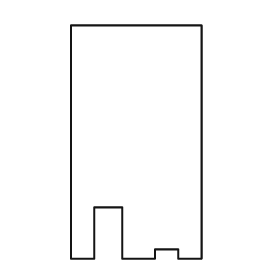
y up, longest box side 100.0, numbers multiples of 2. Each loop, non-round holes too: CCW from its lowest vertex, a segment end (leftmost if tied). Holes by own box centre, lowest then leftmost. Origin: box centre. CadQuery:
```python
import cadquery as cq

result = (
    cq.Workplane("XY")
    .moveTo(-28.0, -50.0)
    .lineTo(-18.0, -50.0)
    .lineTo(-18.0, -28.0)
    .lineTo(-6.0, -28.0)
    .lineTo(-6.0, -50.0)
    .lineTo(8.0, -50.0)
    .lineTo(8.0, -46.0)
    .lineTo(18.0, -46.0)
    .lineTo(18.0, -50.0)
    .lineTo(28.0, -50.0)
    .lineTo(28.0, 50.0)
    .lineTo(-28.0, 50.0)
    .close()
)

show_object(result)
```